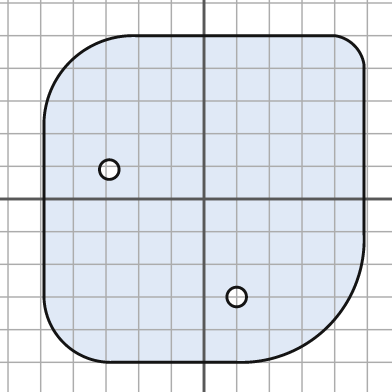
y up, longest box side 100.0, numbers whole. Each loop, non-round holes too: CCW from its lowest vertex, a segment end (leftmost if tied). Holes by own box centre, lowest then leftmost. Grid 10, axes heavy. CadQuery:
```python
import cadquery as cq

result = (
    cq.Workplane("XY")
    .moveTo(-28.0, -50.0)
    .lineTo(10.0, -50.0)
    .threePointArc((38.0, -39.0), (49.0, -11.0))
    .lineTo(49.0, 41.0)
    .threePointArc((46.0, 47.0), (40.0, 50.0))
    .lineTo(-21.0, 50.0)
    .threePointArc((-41.0, 42.0), (-49.0, 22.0))
    .lineTo(-49.0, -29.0)
    .threePointArc((-43.0, -44.0), (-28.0, -50.0))
    .close()
    .moveTo(10.0, -30.0)
    .circle(3.0)
    .moveTo(-29.0, 9.0)
    .circle(3.0)
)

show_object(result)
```